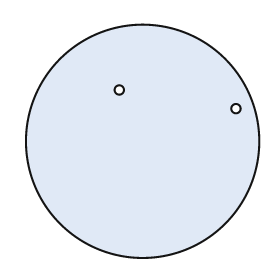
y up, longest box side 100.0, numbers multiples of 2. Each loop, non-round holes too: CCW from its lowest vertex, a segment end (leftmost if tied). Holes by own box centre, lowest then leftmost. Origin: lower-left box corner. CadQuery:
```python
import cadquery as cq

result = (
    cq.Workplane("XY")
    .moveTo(50.0, 50.0)
    .circle(50.0)
    .moveTo(90.0, 64.0)
    .circle(2.0)
    .moveTo(40.0, 72.0)
    .circle(2.0)
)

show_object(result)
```